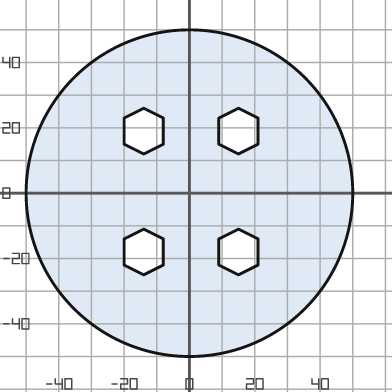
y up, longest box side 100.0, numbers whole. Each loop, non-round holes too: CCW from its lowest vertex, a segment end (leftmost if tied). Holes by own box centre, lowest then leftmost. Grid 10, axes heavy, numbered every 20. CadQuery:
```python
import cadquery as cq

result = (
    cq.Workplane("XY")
    .moveTo(0.0, 0.0)
    .circle(50.0)
    .moveTo(-14.0, -25.0)
    .lineTo(-8.0, -22.0)
    .lineTo(-8.0, -14.0)
    .lineTo(-14.0, -11.0)
    .lineTo(-20.0, -14.0)
    .lineTo(-20.0, -22.0)
    .close()
    .moveTo(15.0, -25.0)
    .lineTo(21.0, -22.0)
    .lineTo(21.0, -14.0)
    .lineTo(15.0, -11.0)
    .lineTo(9.0, -14.0)
    .lineTo(9.0, -22.0)
    .close()
    .moveTo(-14.0, 12.0)
    .lineTo(-8.0, 15.0)
    .lineTo(-8.0, 23.0)
    .lineTo(-14.0, 26.0)
    .lineTo(-20.0, 23.0)
    .lineTo(-20.0, 15.0)
    .close()
    .moveTo(15.0, 12.0)
    .lineTo(21.0, 15.0)
    .lineTo(21.0, 23.0)
    .lineTo(15.0, 26.0)
    .lineTo(9.0, 23.0)
    .lineTo(9.0, 15.0)
    .close()
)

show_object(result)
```